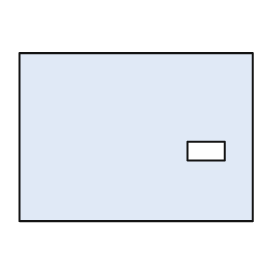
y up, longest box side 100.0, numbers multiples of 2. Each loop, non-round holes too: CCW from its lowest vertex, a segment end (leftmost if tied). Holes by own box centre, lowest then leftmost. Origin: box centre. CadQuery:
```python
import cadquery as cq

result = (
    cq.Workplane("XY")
    .moveTo(-50.0, -36.0)
    .lineTo(50.0, -36.0)
    .lineTo(50.0, 36.0)
    .lineTo(-50.0, 36.0)
    .close()
    .moveTo(22.0, -10.0)
    .lineTo(38.0, -10.0)
    .lineTo(38.0, -2.0)
    .lineTo(22.0, -2.0)
    .close()
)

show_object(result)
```